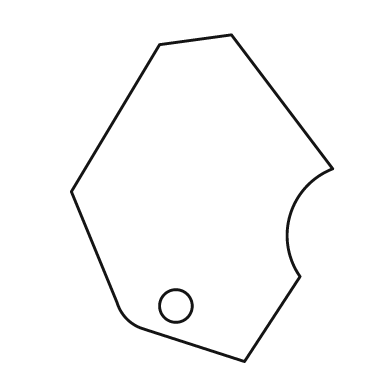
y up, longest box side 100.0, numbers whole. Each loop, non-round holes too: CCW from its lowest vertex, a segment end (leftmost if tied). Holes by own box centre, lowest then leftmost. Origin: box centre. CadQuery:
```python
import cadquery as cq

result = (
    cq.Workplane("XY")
    .moveTo(13.0, -50.0)
    .lineTo(30.0, -24.0)
    .threePointArc((27.0, -5.0), (40.0, 9.0))
    .lineTo(9.0, 50.0)
    .lineTo(-13.0, 47.0)
    .lineTo(-40.0, 2.0)
    .lineTo(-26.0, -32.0)
    .threePointArc((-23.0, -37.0), (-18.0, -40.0))
    .close()
    .moveTo(-8.0, -33.0)
    .circle(5.0)
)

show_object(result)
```